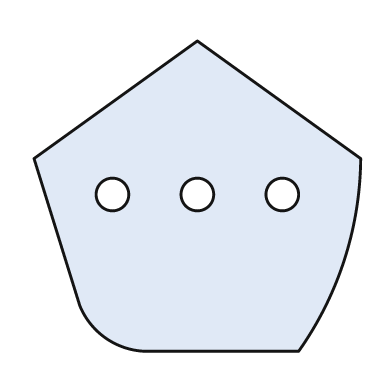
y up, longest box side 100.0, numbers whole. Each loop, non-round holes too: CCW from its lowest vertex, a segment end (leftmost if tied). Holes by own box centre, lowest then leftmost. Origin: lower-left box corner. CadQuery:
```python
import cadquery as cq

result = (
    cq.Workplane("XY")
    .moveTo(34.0, 0.0)
    .lineTo(81.0, 0.0)
    .threePointArc((95.0, 28.0), (100.0, 59.0))
    .lineTo(50.0, 95.0)
    .lineTo(0.0, 59.0)
    .lineTo(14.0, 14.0)
    .threePointArc((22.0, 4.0), (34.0, 0.0))
    .close()
    .moveTo(24.0, 48.0)
    .circle(5.0)
    .moveTo(50.0, 48.0)
    .circle(5.0)
    .moveTo(76.0, 48.0)
    .circle(5.0)
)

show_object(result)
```